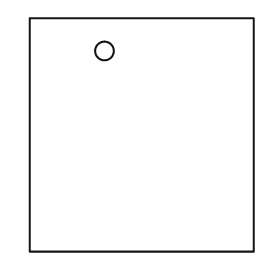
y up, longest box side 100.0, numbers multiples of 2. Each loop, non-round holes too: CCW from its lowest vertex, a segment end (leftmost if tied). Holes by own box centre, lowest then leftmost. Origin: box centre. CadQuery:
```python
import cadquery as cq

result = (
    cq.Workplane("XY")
    .moveTo(-48.0, -50.0)
    .lineTo(48.0, -50.0)
    .lineTo(48.0, 50.0)
    .lineTo(-48.0, 50.0)
    .close()
    .moveTo(-16.0, 36.0)
    .circle(4.0)
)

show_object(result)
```